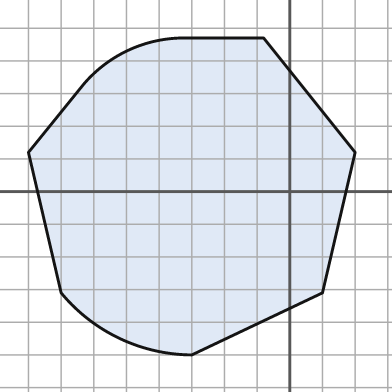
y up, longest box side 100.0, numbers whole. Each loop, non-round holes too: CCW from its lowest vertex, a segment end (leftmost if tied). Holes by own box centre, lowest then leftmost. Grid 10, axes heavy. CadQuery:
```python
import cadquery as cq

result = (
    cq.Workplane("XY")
    .moveTo(-30.0, -50.0)
    .lineTo(10.0, -31.0)
    .lineTo(20.0, 12.0)
    .lineTo(-8.0, 47.0)
    .lineTo(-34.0, 47.0)
    .threePointArc((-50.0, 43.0), (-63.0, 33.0))
    .lineTo(-80.0, 12.0)
    .lineTo(-70.0, -31.0)
    .threePointArc((-52.0, -45.0), (-30.0, -50.0))
    .close()
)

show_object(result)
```